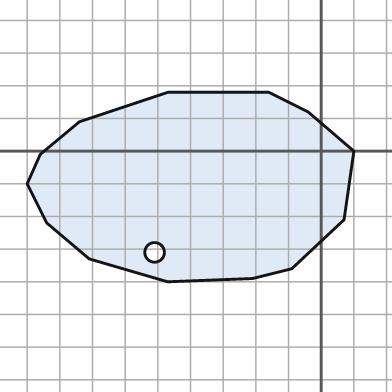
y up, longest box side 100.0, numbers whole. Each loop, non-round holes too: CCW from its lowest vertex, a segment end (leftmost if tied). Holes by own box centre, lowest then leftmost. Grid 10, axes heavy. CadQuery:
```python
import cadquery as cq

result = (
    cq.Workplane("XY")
    .moveTo(-47.0, -40.0)
    .lineTo(-21.0, -39.0)
    .lineTo(-9.0, -36.0)
    .lineTo(7.0, -21.0)
    .lineTo(10.0, 0.0)
    .lineTo(-4.0, 12.0)
    .lineTo(-16.0, 18.0)
    .lineTo(-47.0, 18.0)
    .lineTo(-74.0, 9.0)
    .lineTo(-86.0, -1.0)
    .lineTo(-90.0, -10.0)
    .lineTo(-84.0, -22.0)
    .lineTo(-71.0, -33.0)
    .close()
    .moveTo(-51.0, -31.0)
    .circle(3.0)
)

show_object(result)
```